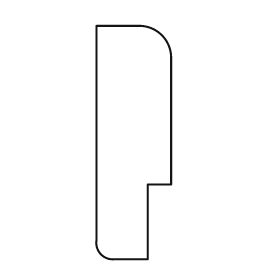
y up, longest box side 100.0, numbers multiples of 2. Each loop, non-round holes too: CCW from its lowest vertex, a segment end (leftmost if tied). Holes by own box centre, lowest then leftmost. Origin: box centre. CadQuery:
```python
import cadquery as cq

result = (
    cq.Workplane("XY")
    .moveTo(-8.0, -50.0)
    .lineTo(6.0, -50.0)
    .lineTo(6.0, -18.0)
    .lineTo(16.0, -18.0)
    .lineTo(16.0, 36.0)
    .threePointArc((12.0, 46.0), (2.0, 50.0))
    .lineTo(-16.0, 50.0)
    .lineTo(-16.0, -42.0)
    .threePointArc((-14.0, -48.0), (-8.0, -50.0))
    .close()
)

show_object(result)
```